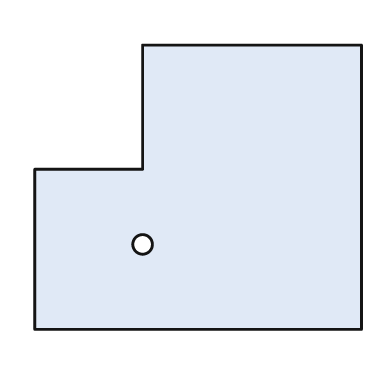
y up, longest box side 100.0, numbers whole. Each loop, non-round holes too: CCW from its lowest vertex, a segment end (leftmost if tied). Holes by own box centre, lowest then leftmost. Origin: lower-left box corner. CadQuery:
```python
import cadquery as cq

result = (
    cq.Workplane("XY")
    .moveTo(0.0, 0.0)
    .lineTo(100.0, 0.0)
    .lineTo(100.0, 87.0)
    .lineTo(33.0, 87.0)
    .lineTo(33.0, 49.0)
    .lineTo(0.0, 49.0)
    .close()
    .moveTo(33.0, 26.0)
    .circle(3.0)
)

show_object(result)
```